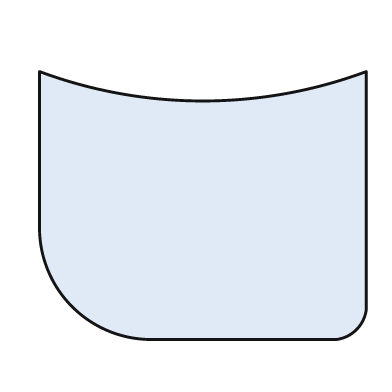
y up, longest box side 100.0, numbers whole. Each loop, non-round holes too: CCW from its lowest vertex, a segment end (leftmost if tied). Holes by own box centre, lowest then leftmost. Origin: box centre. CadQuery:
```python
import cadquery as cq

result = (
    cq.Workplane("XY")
    .moveTo(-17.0, -41.0)
    .lineTo(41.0, -41.0)
    .threePointArc((47.0, -38.0), (50.0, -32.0))
    .lineTo(50.0, 41.0)
    .threePointArc((0.0, 32.0), (-50.0, 41.0))
    .lineTo(-50.0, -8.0)
    .threePointArc((-40.0, -31.0), (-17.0, -41.0))
    .close()
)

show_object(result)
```